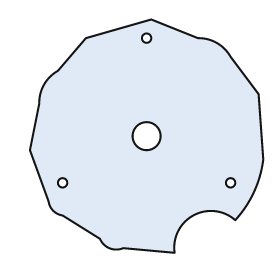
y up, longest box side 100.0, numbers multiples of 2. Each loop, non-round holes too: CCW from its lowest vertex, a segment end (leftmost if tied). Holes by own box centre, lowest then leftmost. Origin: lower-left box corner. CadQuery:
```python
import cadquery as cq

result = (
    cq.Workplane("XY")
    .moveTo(62.0, 0.0)
    .threePointArc((70.0, 16.0), (88.0, 14.0))
    .threePointArc((96.0, 26.0), (100.0, 40.0))
    .lineTo(98.0, 68.0)
    .lineTo(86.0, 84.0)
    .threePointArc((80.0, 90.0), (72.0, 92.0))
    .lineTo(52.0, 100.0)
    .lineTo(24.0, 92.0)
    .lineTo(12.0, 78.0)
    .threePointArc((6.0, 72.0), (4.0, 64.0))
    .lineTo(0.0, 44.0)
    .lineTo(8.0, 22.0)
    .threePointArc((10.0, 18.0), (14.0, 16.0))
    .lineTo(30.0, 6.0)
    .threePointArc((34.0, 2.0), (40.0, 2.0))
    .close()
    .moveTo(14.0, 30.0)
    .circle(2.0)
    .moveTo(86.0, 30.0)
    .circle(2.0)
    .moveTo(50.0, 50.0)
    .circle(6.0)
    .moveTo(50.0, 92.0)
    .circle(2.0)
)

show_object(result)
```